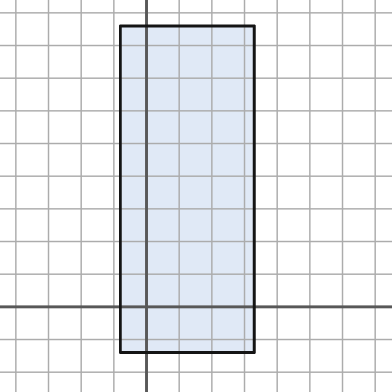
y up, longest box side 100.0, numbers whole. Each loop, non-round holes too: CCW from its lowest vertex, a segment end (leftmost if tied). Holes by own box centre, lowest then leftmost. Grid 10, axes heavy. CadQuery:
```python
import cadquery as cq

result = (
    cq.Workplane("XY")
    .moveTo(-8.0, -14.0)
    .lineTo(33.0, -14.0)
    .lineTo(33.0, 86.0)
    .lineTo(-8.0, 86.0)
    .close()
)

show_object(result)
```